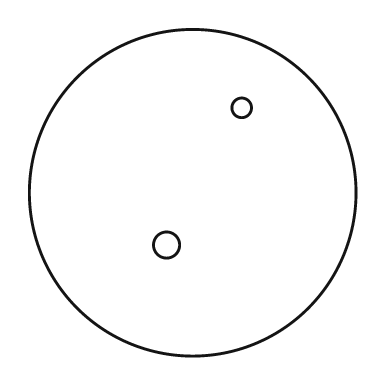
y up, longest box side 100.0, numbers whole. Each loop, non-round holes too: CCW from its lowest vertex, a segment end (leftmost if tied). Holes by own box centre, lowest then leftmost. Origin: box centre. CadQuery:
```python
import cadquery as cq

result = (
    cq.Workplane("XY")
    .moveTo(0.0, 0.0)
    .circle(50.0)
    .moveTo(-8.0, -16.0)
    .circle(4.0)
    .moveTo(15.0, 26.0)
    .circle(3.0)
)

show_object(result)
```